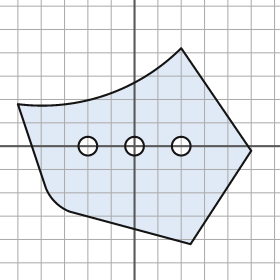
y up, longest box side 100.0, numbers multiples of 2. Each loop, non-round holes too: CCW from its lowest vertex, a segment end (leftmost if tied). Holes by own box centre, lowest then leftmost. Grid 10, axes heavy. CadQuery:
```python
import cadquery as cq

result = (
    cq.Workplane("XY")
    .moveTo(24.0, -42.0)
    .lineTo(50.0, -2.0)
    .lineTo(20.0, 42.0)
    .threePointArc((-12.0, 22.0), (-50.0, 18.0))
    .lineTo(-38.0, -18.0)
    .threePointArc((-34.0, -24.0), (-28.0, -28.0))
    .close()
    .moveTo(-20.0, 0.0)
    .circle(4.0)
    .moveTo(0.0, 0.0)
    .circle(4.0)
    .moveTo(20.0, 0.0)
    .circle(4.0)
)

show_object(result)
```